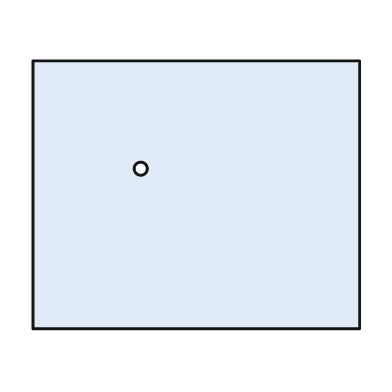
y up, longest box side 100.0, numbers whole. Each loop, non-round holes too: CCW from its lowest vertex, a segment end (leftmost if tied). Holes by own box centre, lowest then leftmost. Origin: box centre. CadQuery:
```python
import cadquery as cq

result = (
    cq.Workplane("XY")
    .moveTo(-50.0, -41.0)
    .lineTo(50.0, -41.0)
    .lineTo(50.0, 41.0)
    .lineTo(-50.0, 41.0)
    .close()
    .moveTo(-17.0, 8.0)
    .circle(2.0)
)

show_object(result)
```